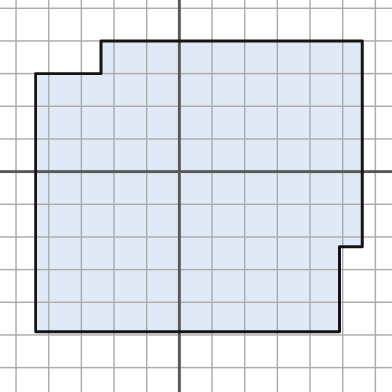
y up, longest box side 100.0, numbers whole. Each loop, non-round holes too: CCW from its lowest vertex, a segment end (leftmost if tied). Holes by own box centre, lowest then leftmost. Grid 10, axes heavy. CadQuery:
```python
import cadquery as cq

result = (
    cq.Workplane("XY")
    .moveTo(-44.0, -49.0)
    .lineTo(49.0, -49.0)
    .lineTo(49.0, -23.0)
    .lineTo(56.0, -23.0)
    .lineTo(56.0, 40.0)
    .lineTo(-24.0, 40.0)
    .lineTo(-24.0, 30.0)
    .lineTo(-44.0, 30.0)
    .close()
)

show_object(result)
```